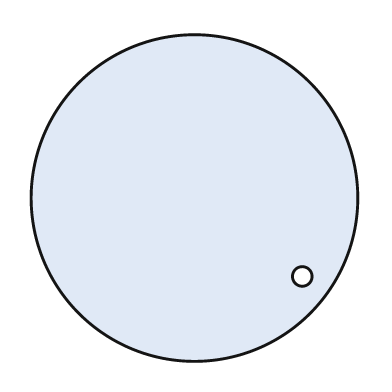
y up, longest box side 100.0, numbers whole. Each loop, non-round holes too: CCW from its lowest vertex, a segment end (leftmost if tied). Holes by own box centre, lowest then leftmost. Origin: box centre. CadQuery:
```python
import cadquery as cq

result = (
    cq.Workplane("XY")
    .moveTo(0.0, 0.0)
    .circle(50.0)
    .moveTo(33.0, -24.0)
    .circle(3.0)
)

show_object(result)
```